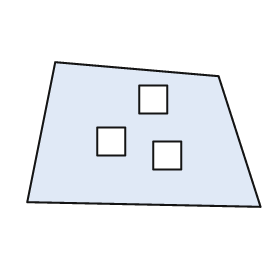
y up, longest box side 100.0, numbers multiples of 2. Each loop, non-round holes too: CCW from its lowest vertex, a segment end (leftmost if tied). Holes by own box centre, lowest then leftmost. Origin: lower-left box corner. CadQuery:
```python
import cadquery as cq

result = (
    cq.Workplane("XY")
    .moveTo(100.0, 0.0)
    .lineTo(82.0, 56.0)
    .lineTo(12.0, 62.0)
    .lineTo(0.0, 2.0)
    .close()
    .moveTo(54.0, 16.0)
    .lineTo(66.0, 16.0)
    .lineTo(66.0, 28.0)
    .lineTo(54.0, 28.0)
    .close()
    .moveTo(30.0, 22.0)
    .lineTo(42.0, 22.0)
    .lineTo(42.0, 34.0)
    .lineTo(30.0, 34.0)
    .close()
    .moveTo(48.0, 40.0)
    .lineTo(60.0, 40.0)
    .lineTo(60.0, 52.0)
    .lineTo(48.0, 52.0)
    .close()
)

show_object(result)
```